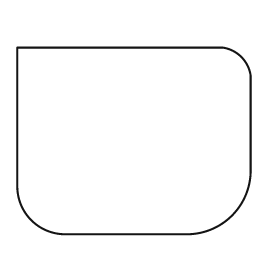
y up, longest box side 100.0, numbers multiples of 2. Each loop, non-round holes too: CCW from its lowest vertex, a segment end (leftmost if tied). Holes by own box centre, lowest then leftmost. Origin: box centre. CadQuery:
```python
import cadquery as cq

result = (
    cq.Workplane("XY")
    .moveTo(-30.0, -40.0)
    .lineTo(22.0, -40.0)
    .threePointArc((42.0, -32.0), (50.0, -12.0))
    .lineTo(50.0, 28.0)
    .threePointArc((46.0, 36.0), (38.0, 40.0))
    .lineTo(-50.0, 40.0)
    .lineTo(-50.0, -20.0)
    .threePointArc((-44.0, -34.0), (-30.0, -40.0))
    .close()
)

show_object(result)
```